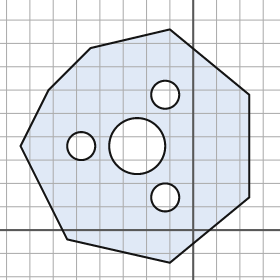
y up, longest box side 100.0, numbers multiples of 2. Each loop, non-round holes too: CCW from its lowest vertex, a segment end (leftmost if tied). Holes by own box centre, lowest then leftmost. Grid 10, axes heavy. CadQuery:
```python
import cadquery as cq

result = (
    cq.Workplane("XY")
    .moveTo(-10.0, -14.0)
    .lineTo(24.0, 14.0)
    .lineTo(24.0, 58.0)
    .lineTo(-10.0, 86.0)
    .lineTo(-44.0, 78.0)
    .lineTo(-62.0, 60.0)
    .lineTo(-74.0, 36.0)
    .lineTo(-54.0, -4.0)
    .close()
    .moveTo(-12.0, 14.0)
    .circle(6.0)
    .moveTo(-48.0, 36.0)
    .circle(6.0)
    .moveTo(-24.0, 36.0)
    .circle(12.0)
    .moveTo(-12.0, 58.0)
    .circle(6.0)
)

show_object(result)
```